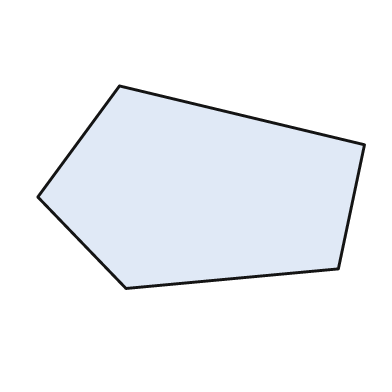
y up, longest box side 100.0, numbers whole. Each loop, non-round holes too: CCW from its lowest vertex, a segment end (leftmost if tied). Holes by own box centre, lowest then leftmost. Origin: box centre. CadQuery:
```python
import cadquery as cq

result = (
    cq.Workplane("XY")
    .moveTo(-23.0, -31.0)
    .lineTo(42.0, -25.0)
    .lineTo(50.0, 13.0)
    .lineTo(-25.0, 31.0)
    .lineTo(-50.0, -3.0)
    .close()
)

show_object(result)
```